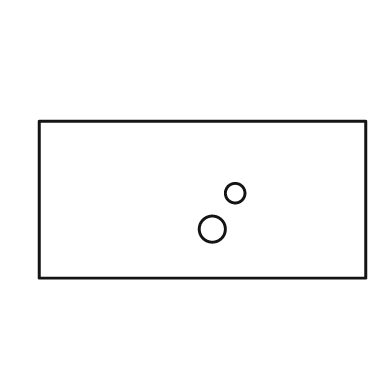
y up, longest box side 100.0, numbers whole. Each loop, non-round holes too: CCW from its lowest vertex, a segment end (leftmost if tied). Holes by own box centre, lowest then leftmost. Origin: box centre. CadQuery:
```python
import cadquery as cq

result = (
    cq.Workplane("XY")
    .moveTo(-50.0, -24.0)
    .lineTo(50.0, -24.0)
    .lineTo(50.0, 24.0)
    .lineTo(-50.0, 24.0)
    .close()
    .moveTo(3.0, -9.0)
    .circle(4.0)
    .moveTo(10.0, 2.0)
    .circle(3.0)
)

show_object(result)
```